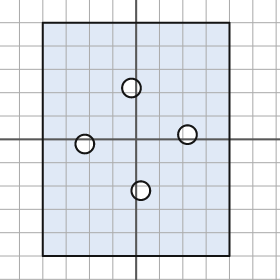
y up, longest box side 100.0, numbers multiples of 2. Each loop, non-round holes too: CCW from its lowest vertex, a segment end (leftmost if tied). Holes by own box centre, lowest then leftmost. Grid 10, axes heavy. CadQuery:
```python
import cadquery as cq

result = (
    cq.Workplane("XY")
    .moveTo(-40.0, -50.0)
    .lineTo(40.0, -50.0)
    .lineTo(40.0, 50.0)
    .lineTo(-40.0, 50.0)
    .close()
    .moveTo(2.0, -22.0)
    .circle(4.0)
    .moveTo(-22.0, -2.0)
    .circle(4.0)
    .moveTo(22.0, 2.0)
    .circle(4.0)
    .moveTo(-2.0, 22.0)
    .circle(4.0)
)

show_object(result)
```